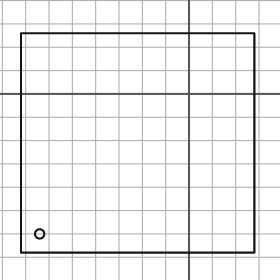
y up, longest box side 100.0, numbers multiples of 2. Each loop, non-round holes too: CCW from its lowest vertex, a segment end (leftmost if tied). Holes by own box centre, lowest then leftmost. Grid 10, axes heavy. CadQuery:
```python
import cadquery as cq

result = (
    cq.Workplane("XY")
    .moveTo(-72.0, -68.0)
    .lineTo(28.0, -68.0)
    .lineTo(28.0, 26.0)
    .lineTo(-72.0, 26.0)
    .close()
    .moveTo(-64.0, -60.0)
    .circle(2.0)
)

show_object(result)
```